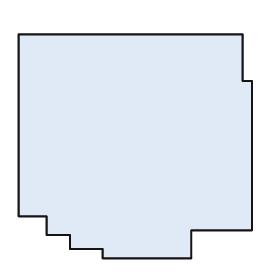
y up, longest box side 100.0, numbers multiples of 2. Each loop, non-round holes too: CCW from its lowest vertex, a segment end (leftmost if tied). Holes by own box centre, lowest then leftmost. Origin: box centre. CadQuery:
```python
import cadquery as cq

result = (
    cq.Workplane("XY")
    .moveTo(-14.0, -48.0)
    .lineTo(24.0, -48.0)
    .lineTo(24.0, -36.0)
    .lineTo(50.0, -36.0)
    .lineTo(50.0, 28.0)
    .lineTo(46.0, 28.0)
    .lineTo(46.0, 48.0)
    .lineTo(-50.0, 48.0)
    .lineTo(-50.0, -30.0)
    .lineTo(-38.0, -30.0)
    .lineTo(-38.0, -38.0)
    .lineTo(-28.0, -38.0)
    .lineTo(-28.0, -44.0)
    .lineTo(-14.0, -44.0)
    .close()
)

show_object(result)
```